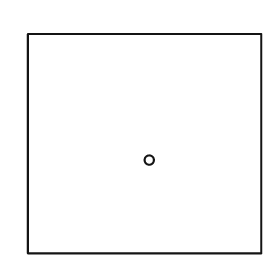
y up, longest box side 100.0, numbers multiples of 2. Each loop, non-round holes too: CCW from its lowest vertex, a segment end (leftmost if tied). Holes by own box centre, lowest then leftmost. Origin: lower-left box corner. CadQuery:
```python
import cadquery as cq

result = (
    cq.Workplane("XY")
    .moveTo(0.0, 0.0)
    .lineTo(100.0, 0.0)
    .lineTo(100.0, 94.0)
    .lineTo(0.0, 94.0)
    .close()
    .moveTo(52.0, 40.0)
    .circle(2.0)
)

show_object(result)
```